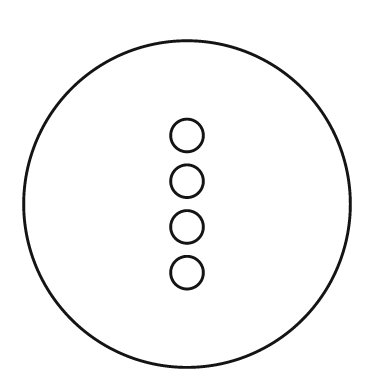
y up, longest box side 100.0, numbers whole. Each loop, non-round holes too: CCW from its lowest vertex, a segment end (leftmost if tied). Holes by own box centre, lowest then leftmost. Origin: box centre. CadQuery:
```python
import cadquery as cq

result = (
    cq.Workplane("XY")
    .moveTo(0.0, 0.0)
    .circle(50.0)
    .moveTo(0.0, -21.0)
    .circle(5.0)
    .moveTo(0.0, -7.0)
    .circle(5.0)
    .moveTo(0.0, 7.0)
    .circle(5.0)
    .moveTo(0.0, 21.0)
    .circle(5.0)
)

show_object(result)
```